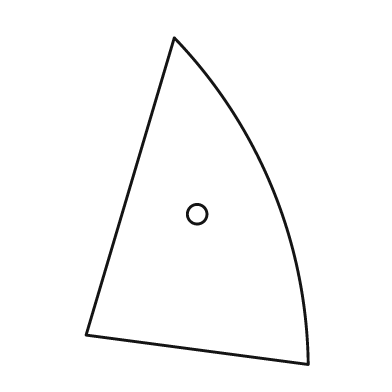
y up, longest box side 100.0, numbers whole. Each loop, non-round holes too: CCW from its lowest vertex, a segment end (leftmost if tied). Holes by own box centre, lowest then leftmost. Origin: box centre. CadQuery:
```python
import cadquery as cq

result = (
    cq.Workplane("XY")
    .moveTo(34.0, -50.0)
    .threePointArc((23.0, 4.0), (-7.0, 50.0))
    .lineTo(-34.0, -41.0)
    .close()
    .moveTo(0.0, -4.0)
    .circle(3.0)
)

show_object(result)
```